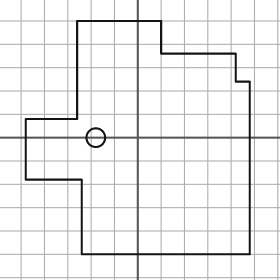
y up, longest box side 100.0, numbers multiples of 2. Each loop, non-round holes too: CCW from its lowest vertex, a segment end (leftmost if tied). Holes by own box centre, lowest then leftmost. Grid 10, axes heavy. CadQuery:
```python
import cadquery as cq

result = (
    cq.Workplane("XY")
    .moveTo(-24.0, -50.0)
    .lineTo(48.0, -50.0)
    .lineTo(48.0, 24.0)
    .lineTo(42.0, 24.0)
    .lineTo(42.0, 36.0)
    .lineTo(10.0, 36.0)
    .lineTo(10.0, 50.0)
    .lineTo(-26.0, 50.0)
    .lineTo(-26.0, 8.0)
    .lineTo(-48.0, 8.0)
    .lineTo(-48.0, -18.0)
    .lineTo(-24.0, -18.0)
    .close()
    .moveTo(-18.0, 0.0)
    .circle(4.0)
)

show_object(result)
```